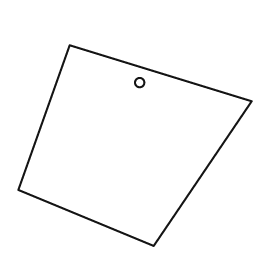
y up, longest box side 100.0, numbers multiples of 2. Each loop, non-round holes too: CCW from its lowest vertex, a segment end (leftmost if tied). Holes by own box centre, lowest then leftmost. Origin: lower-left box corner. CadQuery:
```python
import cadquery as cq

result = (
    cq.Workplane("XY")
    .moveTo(58.0, 0.0)
    .lineTo(100.0, 62.0)
    .lineTo(22.0, 86.0)
    .lineTo(0.0, 24.0)
    .close()
    .moveTo(52.0, 70.0)
    .circle(2.0)
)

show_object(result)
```